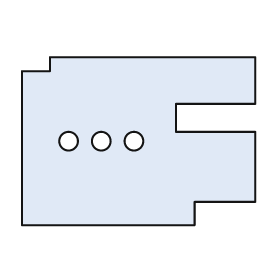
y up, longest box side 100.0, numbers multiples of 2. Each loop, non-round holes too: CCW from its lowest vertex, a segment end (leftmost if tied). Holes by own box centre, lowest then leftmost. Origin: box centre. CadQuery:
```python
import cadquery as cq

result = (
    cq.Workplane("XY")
    .moveTo(-50.0, -36.0)
    .lineTo(24.0, -36.0)
    .lineTo(24.0, -26.0)
    .lineTo(50.0, -26.0)
    .lineTo(50.0, 4.0)
    .lineTo(16.0, 4.0)
    .lineTo(16.0, 16.0)
    .lineTo(50.0, 16.0)
    .lineTo(50.0, 36.0)
    .lineTo(-38.0, 36.0)
    .lineTo(-38.0, 30.0)
    .lineTo(-50.0, 30.0)
    .close()
    .moveTo(-30.0, 0.0)
    .circle(4.0)
    .moveTo(-16.0, 0.0)
    .circle(4.0)
    .moveTo(-2.0, 0.0)
    .circle(4.0)
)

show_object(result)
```